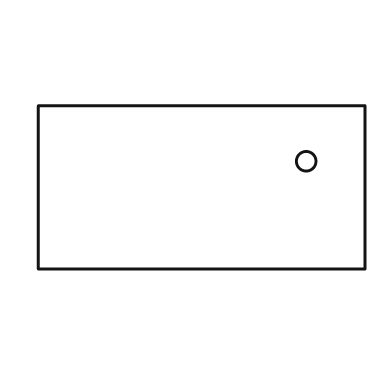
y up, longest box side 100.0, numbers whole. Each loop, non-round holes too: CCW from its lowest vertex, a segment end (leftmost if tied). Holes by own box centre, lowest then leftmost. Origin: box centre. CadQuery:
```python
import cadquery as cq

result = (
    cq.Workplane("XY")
    .moveTo(-50.0, -25.0)
    .lineTo(50.0, -25.0)
    .lineTo(50.0, 25.0)
    .lineTo(-50.0, 25.0)
    .close()
    .moveTo(32.0, 8.0)
    .circle(3.0)
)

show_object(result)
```